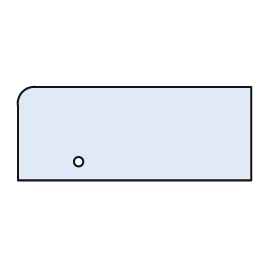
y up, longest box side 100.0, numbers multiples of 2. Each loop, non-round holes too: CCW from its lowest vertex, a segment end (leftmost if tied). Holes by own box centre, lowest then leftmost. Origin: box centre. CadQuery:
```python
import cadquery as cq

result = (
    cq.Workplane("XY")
    .moveTo(-50.0, -20.0)
    .lineTo(50.0, -20.0)
    .lineTo(50.0, 20.0)
    .lineTo(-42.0, 20.0)
    .threePointArc((-48.0, 18.0), (-50.0, 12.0))
    .close()
    .moveTo(-24.0, -12.0)
    .circle(2.0)
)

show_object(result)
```